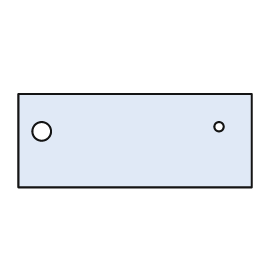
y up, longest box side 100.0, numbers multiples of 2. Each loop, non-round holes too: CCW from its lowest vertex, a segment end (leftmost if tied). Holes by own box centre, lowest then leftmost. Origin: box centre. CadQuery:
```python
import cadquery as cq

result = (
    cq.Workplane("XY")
    .moveTo(-50.0, -20.0)
    .lineTo(50.0, -20.0)
    .lineTo(50.0, 20.0)
    .lineTo(-50.0, 20.0)
    .close()
    .moveTo(-40.0, 4.0)
    .circle(4.0)
    .moveTo(36.0, 6.0)
    .circle(2.0)
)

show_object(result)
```